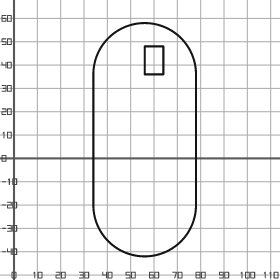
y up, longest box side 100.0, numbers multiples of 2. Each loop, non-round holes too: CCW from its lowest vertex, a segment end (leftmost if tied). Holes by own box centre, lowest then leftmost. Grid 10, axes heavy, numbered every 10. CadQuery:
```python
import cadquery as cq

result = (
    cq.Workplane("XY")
    .moveTo(34.0, -20.0)
    .threePointArc((56.0, -42.0), (78.0, -20.0))
    .lineTo(78.0, 36.0)
    .threePointArc((56.0, 58.0), (34.0, 36.0))
    .close()
    .moveTo(56.0, 36.0)
    .lineTo(64.0, 36.0)
    .lineTo(64.0, 48.0)
    .lineTo(56.0, 48.0)
    .close()
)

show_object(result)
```